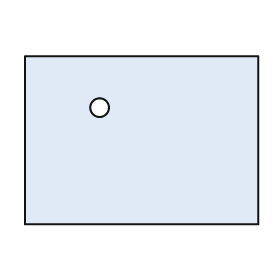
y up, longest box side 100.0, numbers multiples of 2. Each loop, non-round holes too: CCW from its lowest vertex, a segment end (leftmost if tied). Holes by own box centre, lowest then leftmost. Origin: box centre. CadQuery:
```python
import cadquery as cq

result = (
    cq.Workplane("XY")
    .moveTo(-50.0, -36.0)
    .lineTo(50.0, -36.0)
    .lineTo(50.0, 36.0)
    .lineTo(-50.0, 36.0)
    .close()
    .moveTo(-18.0, 14.0)
    .circle(4.0)
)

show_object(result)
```